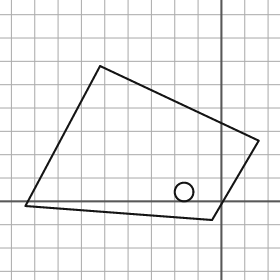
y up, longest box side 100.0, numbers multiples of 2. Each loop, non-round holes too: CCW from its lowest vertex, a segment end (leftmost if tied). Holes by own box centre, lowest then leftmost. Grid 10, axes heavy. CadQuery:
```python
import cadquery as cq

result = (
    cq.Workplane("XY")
    .moveTo(-4.0, -8.0)
    .lineTo(16.0, 26.0)
    .lineTo(-52.0, 58.0)
    .lineTo(-84.0, -2.0)
    .close()
    .moveTo(-16.0, 4.0)
    .circle(4.0)
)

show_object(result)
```